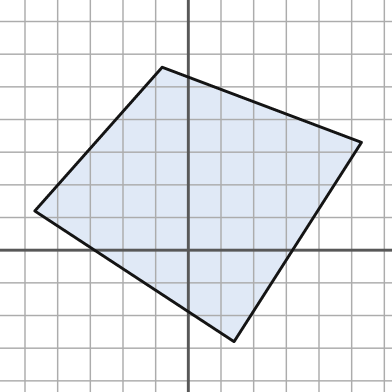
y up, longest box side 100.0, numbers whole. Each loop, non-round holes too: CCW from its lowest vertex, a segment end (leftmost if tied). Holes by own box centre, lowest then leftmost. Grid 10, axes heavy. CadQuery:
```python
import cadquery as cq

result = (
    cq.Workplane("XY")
    .moveTo(14.0, -28.0)
    .lineTo(53.0, 33.0)
    .lineTo(-8.0, 56.0)
    .lineTo(-47.0, 12.0)
    .close()
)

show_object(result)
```